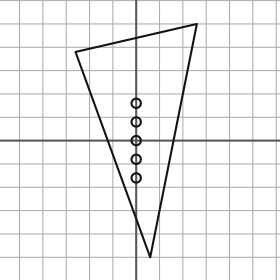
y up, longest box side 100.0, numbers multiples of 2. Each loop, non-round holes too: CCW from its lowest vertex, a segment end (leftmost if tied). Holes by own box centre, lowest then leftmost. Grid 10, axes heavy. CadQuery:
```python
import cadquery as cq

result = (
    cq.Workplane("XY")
    .moveTo(6.0, -50.0)
    .lineTo(26.0, 50.0)
    .lineTo(-26.0, 38.0)
    .close()
    .moveTo(0.0, -16.0)
    .circle(2.0)
    .moveTo(0.0, -8.0)
    .circle(2.0)
    .moveTo(0.0, 0.0)
    .circle(2.0)
    .moveTo(0.0, 8.0)
    .circle(2.0)
    .moveTo(0.0, 16.0)
    .circle(2.0)
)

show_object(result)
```